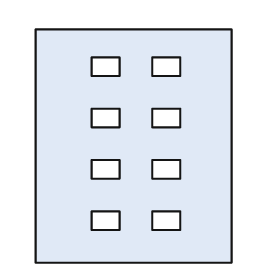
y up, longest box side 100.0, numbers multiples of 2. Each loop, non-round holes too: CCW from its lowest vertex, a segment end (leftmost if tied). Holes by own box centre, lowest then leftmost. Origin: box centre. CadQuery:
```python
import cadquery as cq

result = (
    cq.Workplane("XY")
    .moveTo(-42.0, -50.0)
    .lineTo(42.0, -50.0)
    .lineTo(42.0, 50.0)
    .lineTo(-42.0, 50.0)
    .close()
    .moveTo(-18.0, -36.0)
    .lineTo(-6.0, -36.0)
    .lineTo(-6.0, -28.0)
    .lineTo(-18.0, -28.0)
    .close()
    .moveTo(8.0, -36.0)
    .lineTo(20.0, -36.0)
    .lineTo(20.0, -28.0)
    .lineTo(8.0, -28.0)
    .close()
    .moveTo(-18.0, -14.0)
    .lineTo(-6.0, -14.0)
    .lineTo(-6.0, -6.0)
    .lineTo(-18.0, -6.0)
    .close()
    .moveTo(8.0, -14.0)
    .lineTo(20.0, -14.0)
    .lineTo(20.0, -6.0)
    .lineTo(8.0, -6.0)
    .close()
    .moveTo(-18.0, 8.0)
    .lineTo(-6.0, 8.0)
    .lineTo(-6.0, 16.0)
    .lineTo(-18.0, 16.0)
    .close()
    .moveTo(8.0, 8.0)
    .lineTo(20.0, 8.0)
    .lineTo(20.0, 16.0)
    .lineTo(8.0, 16.0)
    .close()
    .moveTo(-18.0, 30.0)
    .lineTo(-6.0, 30.0)
    .lineTo(-6.0, 38.0)
    .lineTo(-18.0, 38.0)
    .close()
    .moveTo(8.0, 30.0)
    .lineTo(20.0, 30.0)
    .lineTo(20.0, 38.0)
    .lineTo(8.0, 38.0)
    .close()
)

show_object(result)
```